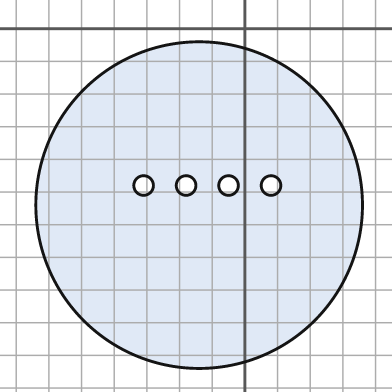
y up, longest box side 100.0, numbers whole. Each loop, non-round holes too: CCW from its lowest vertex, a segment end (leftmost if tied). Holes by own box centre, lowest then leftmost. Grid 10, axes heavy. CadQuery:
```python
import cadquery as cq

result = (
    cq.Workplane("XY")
    .moveTo(-14.0, -54.0)
    .circle(50.0)
    .moveTo(-31.0, -48.0)
    .circle(3.0)
    .moveTo(-18.0, -48.0)
    .circle(3.0)
    .moveTo(-5.0, -48.0)
    .circle(3.0)
    .moveTo(8.0, -48.0)
    .circle(3.0)
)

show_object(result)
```